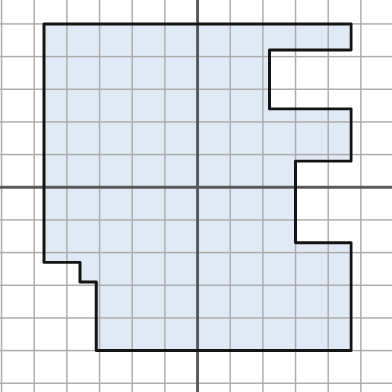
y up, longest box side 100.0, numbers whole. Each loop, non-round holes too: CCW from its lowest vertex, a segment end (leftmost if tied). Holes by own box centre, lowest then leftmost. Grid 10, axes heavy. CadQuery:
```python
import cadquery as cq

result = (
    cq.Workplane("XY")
    .moveTo(-31.0, -50.0)
    .lineTo(47.0, -50.0)
    .lineTo(47.0, -17.0)
    .lineTo(30.0, -17.0)
    .lineTo(30.0, 8.0)
    .lineTo(47.0, 8.0)
    .lineTo(47.0, 24.0)
    .lineTo(22.0, 24.0)
    .lineTo(22.0, 42.0)
    .lineTo(47.0, 42.0)
    .lineTo(47.0, 50.0)
    .lineTo(-47.0, 50.0)
    .lineTo(-47.0, -23.0)
    .lineTo(-36.0, -23.0)
    .lineTo(-36.0, -29.0)
    .lineTo(-31.0, -29.0)
    .close()
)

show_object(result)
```